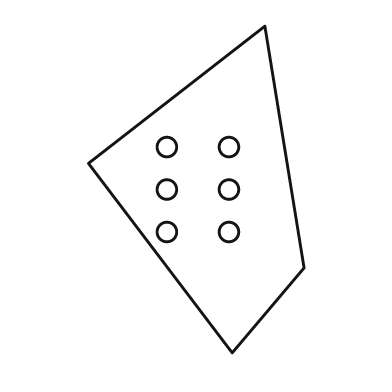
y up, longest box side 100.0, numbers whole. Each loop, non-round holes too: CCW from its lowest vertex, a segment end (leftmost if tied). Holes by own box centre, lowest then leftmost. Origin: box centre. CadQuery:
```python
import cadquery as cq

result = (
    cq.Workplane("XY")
    .moveTo(11.0, -50.0)
    .lineTo(33.0, -24.0)
    .lineTo(21.0, 50.0)
    .lineTo(-33.0, 8.0)
    .close()
    .moveTo(-9.0, -13.0)
    .circle(3.0)
    .moveTo(10.0, -13.0)
    .circle(3.0)
    .moveTo(-9.0, 0.0)
    .circle(3.0)
    .moveTo(10.0, 0.0)
    .circle(3.0)
    .moveTo(-9.0, 13.0)
    .circle(3.0)
    .moveTo(10.0, 13.0)
    .circle(3.0)
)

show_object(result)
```